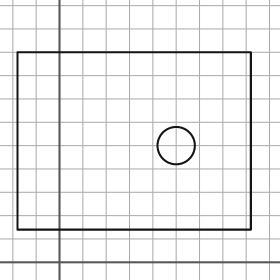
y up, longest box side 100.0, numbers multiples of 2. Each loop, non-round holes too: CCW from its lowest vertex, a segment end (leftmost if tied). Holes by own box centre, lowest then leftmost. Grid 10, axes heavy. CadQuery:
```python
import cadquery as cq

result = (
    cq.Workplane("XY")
    .moveTo(-18.0, 14.0)
    .lineTo(82.0, 14.0)
    .lineTo(82.0, 90.0)
    .lineTo(-18.0, 90.0)
    .close()
    .moveTo(50.0, 50.0)
    .circle(8.0)
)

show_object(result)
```